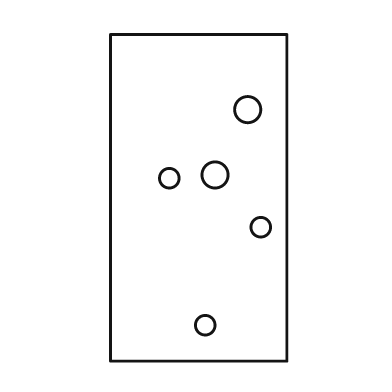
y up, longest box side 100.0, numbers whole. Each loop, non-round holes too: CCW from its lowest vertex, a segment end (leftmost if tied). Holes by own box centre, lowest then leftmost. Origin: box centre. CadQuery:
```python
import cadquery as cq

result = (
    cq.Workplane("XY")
    .moveTo(-27.0, -50.0)
    .lineTo(27.0, -50.0)
    .lineTo(27.0, 50.0)
    .lineTo(-27.0, 50.0)
    .close()
    .moveTo(2.0, -39.0)
    .circle(3.0)
    .moveTo(19.0, -9.0)
    .circle(3.0)
    .moveTo(-9.0, 6.0)
    .circle(3.0)
    .moveTo(5.0, 7.0)
    .circle(4.0)
    .moveTo(15.0, 27.0)
    .circle(4.0)
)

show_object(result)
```